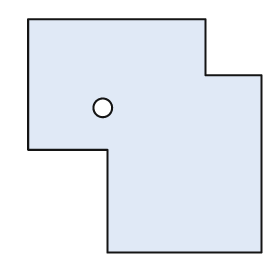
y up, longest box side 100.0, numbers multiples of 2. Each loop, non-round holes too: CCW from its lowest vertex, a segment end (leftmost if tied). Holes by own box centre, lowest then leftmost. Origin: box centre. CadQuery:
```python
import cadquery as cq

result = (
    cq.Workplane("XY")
    .moveTo(-16.0, -50.0)
    .lineTo(50.0, -50.0)
    .lineTo(50.0, 26.0)
    .lineTo(26.0, 26.0)
    .lineTo(26.0, 50.0)
    .lineTo(-50.0, 50.0)
    .lineTo(-50.0, -6.0)
    .lineTo(-16.0, -6.0)
    .close()
    .moveTo(-18.0, 12.0)
    .circle(4.0)
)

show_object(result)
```